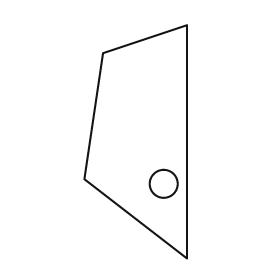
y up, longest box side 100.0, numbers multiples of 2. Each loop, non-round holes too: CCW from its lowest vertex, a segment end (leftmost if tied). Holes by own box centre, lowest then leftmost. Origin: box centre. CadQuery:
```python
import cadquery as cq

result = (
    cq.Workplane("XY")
    .moveTo(22.0, -50.0)
    .lineTo(22.0, 50.0)
    .lineTo(-14.0, 38.0)
    .lineTo(-22.0, -16.0)
    .close()
    .moveTo(12.0, -18.0)
    .circle(6.0)
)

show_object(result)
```